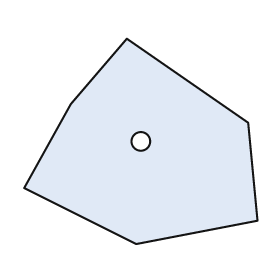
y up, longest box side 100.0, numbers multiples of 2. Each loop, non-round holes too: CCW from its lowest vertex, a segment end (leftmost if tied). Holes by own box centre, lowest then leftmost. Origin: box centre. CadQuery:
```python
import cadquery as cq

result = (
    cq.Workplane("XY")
    .moveTo(-2.0, -44.0)
    .lineTo(50.0, -34.0)
    .lineTo(46.0, 8.0)
    .lineTo(-6.0, 44.0)
    .lineTo(-30.0, 16.0)
    .lineTo(-50.0, -20.0)
    .close()
    .moveTo(0.0, 0.0)
    .circle(4.0)
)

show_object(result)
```